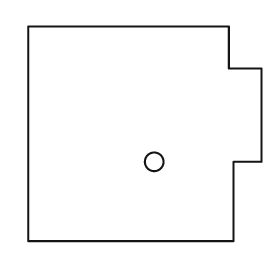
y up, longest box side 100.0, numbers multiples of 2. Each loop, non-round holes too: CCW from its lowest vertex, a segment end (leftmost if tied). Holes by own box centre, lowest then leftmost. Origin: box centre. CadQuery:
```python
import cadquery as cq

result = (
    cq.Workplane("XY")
    .moveTo(-50.0, -46.0)
    .lineTo(38.0, -46.0)
    .lineTo(38.0, -12.0)
    .lineTo(50.0, -12.0)
    .lineTo(50.0, 28.0)
    .lineTo(36.0, 28.0)
    .lineTo(36.0, 46.0)
    .lineTo(-50.0, 46.0)
    .close()
    .moveTo(4.0, -12.0)
    .circle(4.0)
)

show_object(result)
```